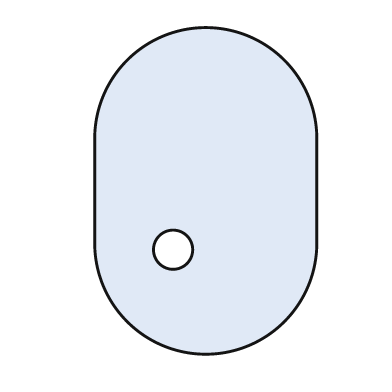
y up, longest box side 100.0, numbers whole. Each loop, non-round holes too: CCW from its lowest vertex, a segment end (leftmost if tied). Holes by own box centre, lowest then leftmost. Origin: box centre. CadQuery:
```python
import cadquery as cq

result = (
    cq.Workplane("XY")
    .moveTo(-34.0, -16.0)
    .threePointArc((0.0, -50.0), (34.0, -16.0))
    .lineTo(34.0, 16.0)
    .threePointArc((0.0, 50.0), (-34.0, 16.0))
    .close()
    .moveTo(-10.0, -18.0)
    .circle(6.0)
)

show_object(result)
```